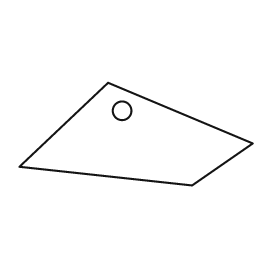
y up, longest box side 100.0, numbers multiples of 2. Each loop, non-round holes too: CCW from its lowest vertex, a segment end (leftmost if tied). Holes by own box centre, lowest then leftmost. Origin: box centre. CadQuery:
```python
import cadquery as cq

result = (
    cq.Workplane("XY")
    .moveTo(24.0, -22.0)
    .lineTo(50.0, -4.0)
    .lineTo(-12.0, 22.0)
    .lineTo(-50.0, -14.0)
    .close()
    .moveTo(-6.0, 10.0)
    .circle(4.0)
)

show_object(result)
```